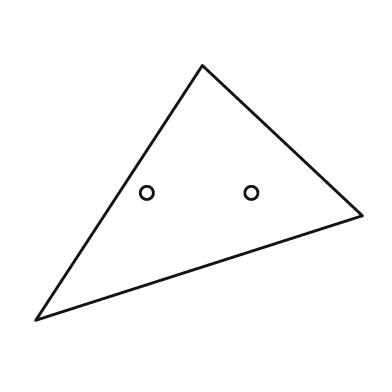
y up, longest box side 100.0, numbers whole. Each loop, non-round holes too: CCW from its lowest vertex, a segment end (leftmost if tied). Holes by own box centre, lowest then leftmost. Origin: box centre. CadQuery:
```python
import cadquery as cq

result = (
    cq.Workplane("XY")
    .moveTo(-50.0, -39.0)
    .lineTo(50.0, -7.0)
    .lineTo(1.0, 39.0)
    .close()
    .moveTo(-16.0, 0.0)
    .circle(2.0)
    .moveTo(16.0, 0.0)
    .circle(2.0)
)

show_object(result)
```